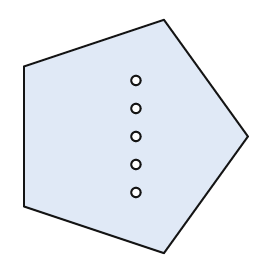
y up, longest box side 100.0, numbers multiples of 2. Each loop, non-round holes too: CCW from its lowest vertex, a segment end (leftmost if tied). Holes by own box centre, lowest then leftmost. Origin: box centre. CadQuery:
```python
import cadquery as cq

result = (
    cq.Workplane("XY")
    .moveTo(12.0, -50.0)
    .lineTo(48.0, 0.0)
    .lineTo(12.0, 50.0)
    .lineTo(-48.0, 30.0)
    .lineTo(-48.0, -30.0)
    .close()
    .moveTo(0.0, -24.0)
    .circle(2.0)
    .moveTo(0.0, -12.0)
    .circle(2.0)
    .moveTo(0.0, 0.0)
    .circle(2.0)
    .moveTo(0.0, 12.0)
    .circle(2.0)
    .moveTo(0.0, 24.0)
    .circle(2.0)
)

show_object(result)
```